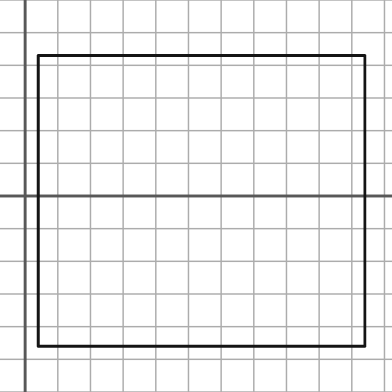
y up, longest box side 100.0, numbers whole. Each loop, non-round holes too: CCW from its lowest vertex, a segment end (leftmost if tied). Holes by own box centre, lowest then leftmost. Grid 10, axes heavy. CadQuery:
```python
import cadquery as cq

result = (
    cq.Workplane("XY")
    .moveTo(4.0, -46.0)
    .lineTo(104.0, -46.0)
    .lineTo(104.0, 43.0)
    .lineTo(4.0, 43.0)
    .close()
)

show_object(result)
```